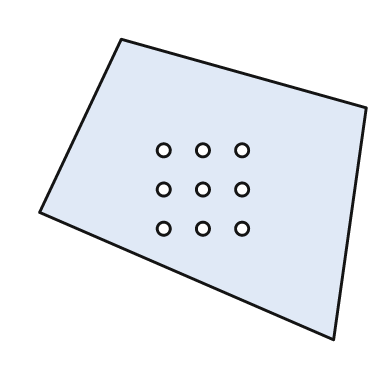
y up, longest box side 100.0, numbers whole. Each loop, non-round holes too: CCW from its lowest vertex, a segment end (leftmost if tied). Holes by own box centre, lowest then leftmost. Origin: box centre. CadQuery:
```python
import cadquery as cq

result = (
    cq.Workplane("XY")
    .moveTo(40.0, -46.0)
    .lineTo(50.0, 25.0)
    .lineTo(-25.0, 46.0)
    .lineTo(-50.0, -7.0)
    .close()
    .moveTo(-12.0, -12.0)
    .circle(2.0)
    .moveTo(0.0, -12.0)
    .circle(2.0)
    .moveTo(12.0, -12.0)
    .circle(2.0)
    .moveTo(-12.0, 0.0)
    .circle(2.0)
    .moveTo(0.0, 0.0)
    .circle(2.0)
    .moveTo(12.0, 0.0)
    .circle(2.0)
    .moveTo(-12.0, 12.0)
    .circle(2.0)
    .moveTo(0.0, 12.0)
    .circle(2.0)
    .moveTo(12.0, 12.0)
    .circle(2.0)
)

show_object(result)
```